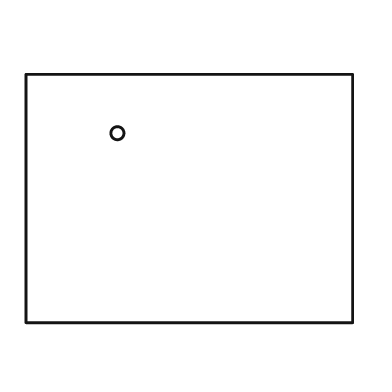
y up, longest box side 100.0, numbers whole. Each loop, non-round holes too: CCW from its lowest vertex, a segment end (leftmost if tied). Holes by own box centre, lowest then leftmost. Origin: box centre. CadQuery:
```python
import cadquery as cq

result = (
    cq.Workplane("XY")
    .moveTo(-50.0, -38.0)
    .lineTo(50.0, -38.0)
    .lineTo(50.0, 38.0)
    .lineTo(-50.0, 38.0)
    .close()
    .moveTo(-22.0, 20.0)
    .circle(2.0)
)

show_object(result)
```